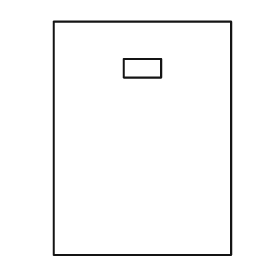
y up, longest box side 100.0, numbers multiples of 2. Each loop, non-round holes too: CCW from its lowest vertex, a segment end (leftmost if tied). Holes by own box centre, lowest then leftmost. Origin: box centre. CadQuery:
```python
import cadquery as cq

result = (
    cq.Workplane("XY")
    .moveTo(-38.0, -50.0)
    .lineTo(38.0, -50.0)
    .lineTo(38.0, 50.0)
    .lineTo(-38.0, 50.0)
    .close()
    .moveTo(-8.0, 26.0)
    .lineTo(8.0, 26.0)
    .lineTo(8.0, 34.0)
    .lineTo(-8.0, 34.0)
    .close()
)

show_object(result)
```